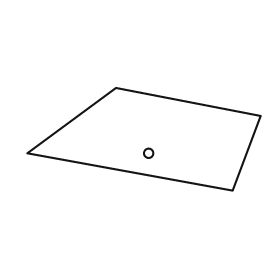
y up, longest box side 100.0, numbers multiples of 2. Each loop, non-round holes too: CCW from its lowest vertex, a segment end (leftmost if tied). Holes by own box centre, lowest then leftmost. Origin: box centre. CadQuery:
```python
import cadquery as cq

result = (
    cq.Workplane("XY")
    .moveTo(38.0, -22.0)
    .lineTo(50.0, 10.0)
    .lineTo(-12.0, 22.0)
    .lineTo(-50.0, -6.0)
    .close()
    .moveTo(2.0, -6.0)
    .circle(2.0)
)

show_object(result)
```